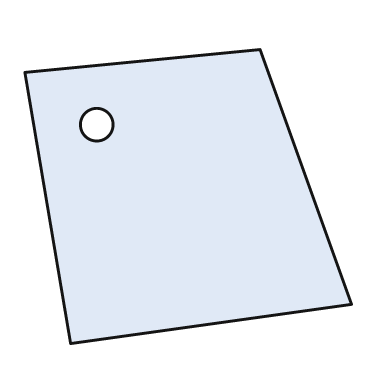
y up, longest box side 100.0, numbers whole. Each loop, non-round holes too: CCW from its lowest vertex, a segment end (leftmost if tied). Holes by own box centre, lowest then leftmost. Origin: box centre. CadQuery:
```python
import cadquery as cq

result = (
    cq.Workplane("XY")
    .moveTo(-36.0, -45.0)
    .lineTo(50.0, -33.0)
    .lineTo(22.0, 45.0)
    .lineTo(-50.0, 38.0)
    .close()
    .moveTo(-28.0, 22.0)
    .circle(5.0)
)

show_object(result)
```